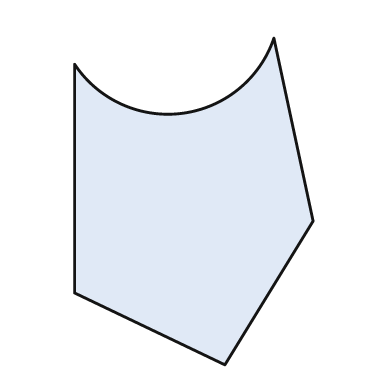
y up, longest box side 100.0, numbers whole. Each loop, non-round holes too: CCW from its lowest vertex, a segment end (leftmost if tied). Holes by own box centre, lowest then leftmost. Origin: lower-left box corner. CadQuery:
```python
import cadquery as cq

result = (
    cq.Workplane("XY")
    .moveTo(46.0, 0.0)
    .lineTo(73.0, 44.0)
    .lineTo(61.0, 100.0)
    .threePointArc((33.0, 77.0), (0.0, 92.0))
    .lineTo(0.0, 22.0)
    .close()
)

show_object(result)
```